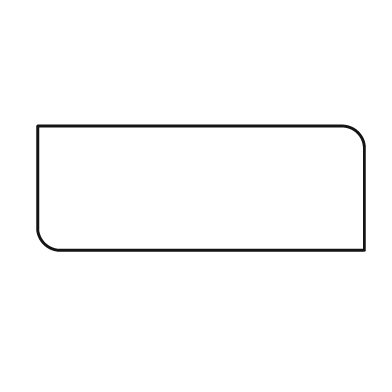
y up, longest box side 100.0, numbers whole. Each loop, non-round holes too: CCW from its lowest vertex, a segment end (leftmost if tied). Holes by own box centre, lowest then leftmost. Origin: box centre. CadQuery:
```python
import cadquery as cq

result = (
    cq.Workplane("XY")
    .moveTo(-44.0, -19.0)
    .lineTo(50.0, -19.0)
    .lineTo(50.0, 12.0)
    .threePointArc((48.0, 17.0), (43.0, 19.0))
    .lineTo(-50.0, 19.0)
    .lineTo(-50.0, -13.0)
    .threePointArc((-48.0, -17.0), (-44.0, -19.0))
    .close()
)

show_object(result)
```